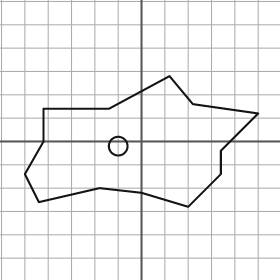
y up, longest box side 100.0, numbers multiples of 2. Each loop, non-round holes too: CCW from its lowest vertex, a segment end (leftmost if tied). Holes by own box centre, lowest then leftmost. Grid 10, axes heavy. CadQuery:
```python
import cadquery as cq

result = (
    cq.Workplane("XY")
    .moveTo(20.0, -28.0)
    .lineTo(34.0, -14.0)
    .lineTo(34.0, -4.0)
    .lineTo(50.0, 12.0)
    .lineTo(22.0, 16.0)
    .lineTo(12.0, 28.0)
    .lineTo(-14.0, 14.0)
    .lineTo(-42.0, 14.0)
    .lineTo(-42.0, 0.0)
    .lineTo(-50.0, -14.0)
    .lineTo(-44.0, -26.0)
    .lineTo(-18.0, -20.0)
    .lineTo(0.0, -22.0)
    .close()
    .moveTo(-10.0, -2.0)
    .circle(4.0)
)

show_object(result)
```